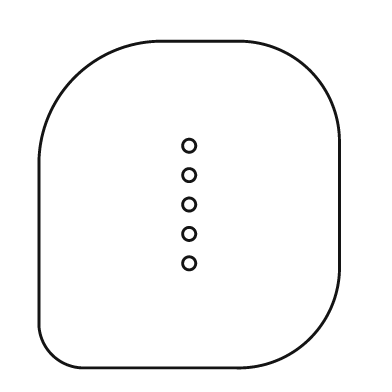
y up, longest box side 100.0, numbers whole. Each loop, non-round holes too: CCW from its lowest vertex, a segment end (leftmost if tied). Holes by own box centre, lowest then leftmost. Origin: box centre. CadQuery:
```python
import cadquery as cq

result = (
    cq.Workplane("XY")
    .moveTo(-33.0, -50.0)
    .lineTo(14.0, -50.0)
    .threePointArc((37.0, -41.0), (46.0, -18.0))
    .lineTo(46.0, 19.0)
    .threePointArc((37.0, 41.0), (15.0, 50.0))
    .lineTo(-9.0, 50.0)
    .threePointArc((-35.0, 39.0), (-46.0, 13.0))
    .lineTo(-46.0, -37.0)
    .threePointArc((-42.0, -46.0), (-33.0, -50.0))
    .close()
    .moveTo(0.0, -18.0)
    .circle(2.0)
    .moveTo(0.0, -9.0)
    .circle(2.0)
    .moveTo(0.0, 0.0)
    .circle(2.0)
    .moveTo(0.0, 9.0)
    .circle(2.0)
    .moveTo(0.0, 18.0)
    .circle(2.0)
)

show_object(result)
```